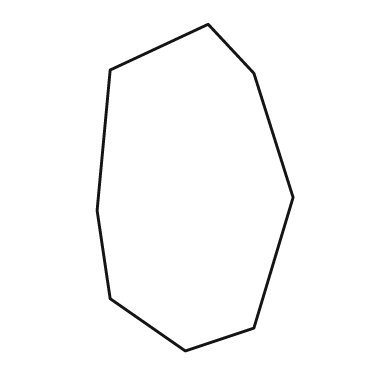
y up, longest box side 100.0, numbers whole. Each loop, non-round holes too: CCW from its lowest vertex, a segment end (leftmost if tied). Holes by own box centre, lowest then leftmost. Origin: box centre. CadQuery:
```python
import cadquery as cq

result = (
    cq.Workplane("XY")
    .moveTo(-3.0, -50.0)
    .lineTo(18.0, -43.0)
    .lineTo(30.0, -3.0)
    .lineTo(18.0, 35.0)
    .lineTo(4.0, 50.0)
    .lineTo(-26.0, 36.0)
    .lineTo(-30.0, -7.0)
    .lineTo(-26.0, -34.0)
    .close()
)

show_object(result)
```